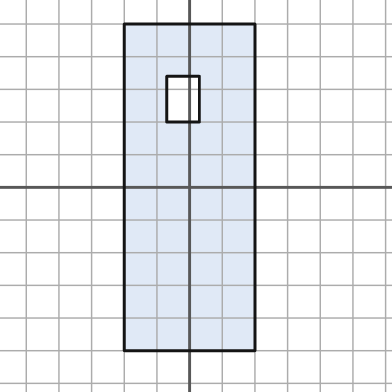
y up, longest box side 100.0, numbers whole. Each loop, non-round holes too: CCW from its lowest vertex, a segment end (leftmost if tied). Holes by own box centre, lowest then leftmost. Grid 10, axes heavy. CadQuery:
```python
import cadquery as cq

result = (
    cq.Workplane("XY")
    .moveTo(-20.0, -50.0)
    .lineTo(20.0, -50.0)
    .lineTo(20.0, 50.0)
    .lineTo(-20.0, 50.0)
    .close()
    .moveTo(-7.0, 20.0)
    .lineTo(3.0, 20.0)
    .lineTo(3.0, 34.0)
    .lineTo(-7.0, 34.0)
    .close()
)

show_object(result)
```